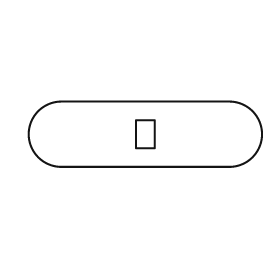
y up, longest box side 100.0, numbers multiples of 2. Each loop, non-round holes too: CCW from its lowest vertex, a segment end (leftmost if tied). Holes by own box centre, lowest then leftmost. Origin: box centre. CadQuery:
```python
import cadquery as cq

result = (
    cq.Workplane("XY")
    .moveTo(-36.0, -14.0)
    .lineTo(36.0, -14.0)
    .threePointArc((50.0, 0.0), (36.0, 14.0))
    .lineTo(-36.0, 14.0)
    .threePointArc((-50.0, 0.0), (-36.0, -14.0))
    .close()
    .moveTo(-4.0, -6.0)
    .lineTo(4.0, -6.0)
    .lineTo(4.0, 6.0)
    .lineTo(-4.0, 6.0)
    .close()
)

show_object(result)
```